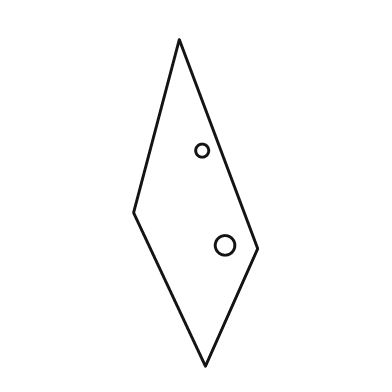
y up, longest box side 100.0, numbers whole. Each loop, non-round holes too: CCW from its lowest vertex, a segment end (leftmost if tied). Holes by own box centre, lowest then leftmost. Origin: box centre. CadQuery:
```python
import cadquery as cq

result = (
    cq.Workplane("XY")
    .moveTo(3.0, -50.0)
    .lineTo(19.0, -14.0)
    .lineTo(-5.0, 50.0)
    .lineTo(-19.0, -3.0)
    .close()
    .moveTo(9.0, -13.0)
    .circle(3.0)
    .moveTo(2.0, 16.0)
    .circle(2.0)
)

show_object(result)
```